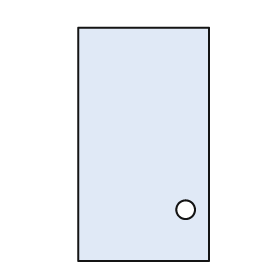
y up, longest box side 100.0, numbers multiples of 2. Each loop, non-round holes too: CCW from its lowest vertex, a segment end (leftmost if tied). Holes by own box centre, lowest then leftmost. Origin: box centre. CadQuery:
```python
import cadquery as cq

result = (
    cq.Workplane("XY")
    .moveTo(-28.0, -50.0)
    .lineTo(28.0, -50.0)
    .lineTo(28.0, 50.0)
    .lineTo(-28.0, 50.0)
    .close()
    .moveTo(18.0, -28.0)
    .circle(4.0)
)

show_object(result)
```